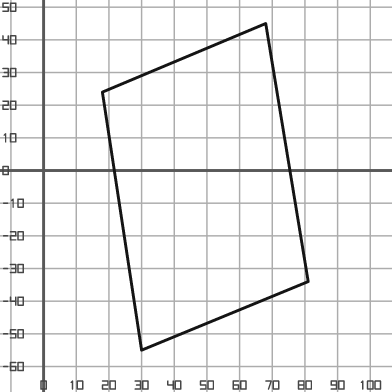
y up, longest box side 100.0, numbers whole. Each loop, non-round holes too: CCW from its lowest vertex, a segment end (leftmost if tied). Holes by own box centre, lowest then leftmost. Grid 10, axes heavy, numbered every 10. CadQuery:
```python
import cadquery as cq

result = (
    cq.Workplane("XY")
    .moveTo(30.0, -55.0)
    .lineTo(81.0, -34.0)
    .lineTo(68.0, 45.0)
    .lineTo(18.0, 24.0)
    .close()
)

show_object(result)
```